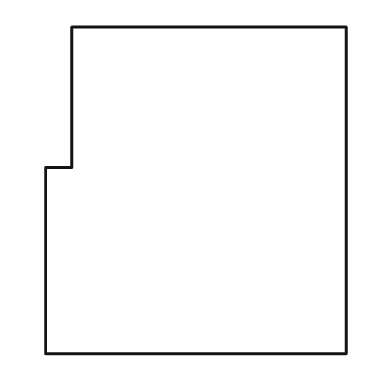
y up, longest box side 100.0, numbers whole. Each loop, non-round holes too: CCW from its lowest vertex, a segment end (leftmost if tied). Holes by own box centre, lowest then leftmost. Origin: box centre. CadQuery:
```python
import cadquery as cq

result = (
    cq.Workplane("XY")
    .moveTo(-46.0, -50.0)
    .lineTo(46.0, -50.0)
    .lineTo(46.0, 50.0)
    .lineTo(-38.0, 50.0)
    .lineTo(-38.0, 7.0)
    .lineTo(-46.0, 7.0)
    .close()
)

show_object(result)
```